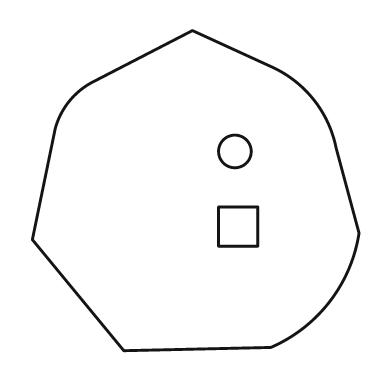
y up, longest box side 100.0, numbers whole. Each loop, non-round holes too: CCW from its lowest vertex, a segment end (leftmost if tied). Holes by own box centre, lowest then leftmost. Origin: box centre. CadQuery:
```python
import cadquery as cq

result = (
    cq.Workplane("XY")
    .moveTo(-22.0, -49.0)
    .lineTo(23.0, -48.0)
    .threePointArc((41.0, -34.0), (50.0, -13.0))
    .lineTo(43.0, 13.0)
    .threePointArc((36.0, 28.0), (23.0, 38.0))
    .lineTo(-1.0, 49.0)
    .lineTo(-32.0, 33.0)
    .threePointArc((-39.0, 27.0), (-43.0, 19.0))
    .lineTo(-50.0, -15.0)
    .close()
    .moveTo(7.0, -17.0)
    .lineTo(19.0, -17.0)
    .lineTo(19.0, -5.0)
    .lineTo(7.0, -5.0)
    .close()
    .moveTo(12.0, 12.0)
    .circle(5.0)
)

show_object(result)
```